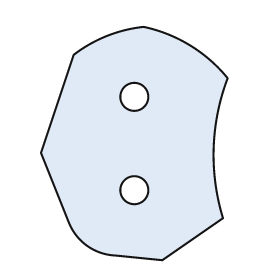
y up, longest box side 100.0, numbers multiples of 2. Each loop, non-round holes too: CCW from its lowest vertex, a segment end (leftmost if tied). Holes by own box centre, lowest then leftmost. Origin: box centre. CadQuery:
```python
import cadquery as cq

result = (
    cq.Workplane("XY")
    .moveTo(12.0, -50.0)
    .lineTo(38.0, -32.0)
    .threePointArc((34.0, -2.0), (40.0, 28.0))
    .threePointArc((24.0, 42.0), (4.0, 50.0))
    .threePointArc((-12.0, 46.0), (-26.0, 38.0))
    .lineTo(-40.0, -4.0)
    .lineTo(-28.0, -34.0)
    .threePointArc((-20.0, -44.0), (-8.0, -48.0))
    .close()
    .moveTo(0.0, -20.0)
    .circle(6.0)
    .moveTo(0.0, 20.0)
    .circle(6.0)
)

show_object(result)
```